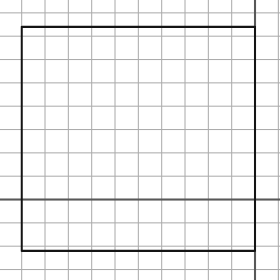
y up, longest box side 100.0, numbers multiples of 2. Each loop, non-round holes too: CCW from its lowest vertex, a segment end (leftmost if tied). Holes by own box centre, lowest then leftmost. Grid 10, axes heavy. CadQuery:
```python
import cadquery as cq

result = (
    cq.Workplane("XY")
    .moveTo(-100.0, -22.0)
    .lineTo(0.0, -22.0)
    .lineTo(0.0, 74.0)
    .lineTo(-100.0, 74.0)
    .close()
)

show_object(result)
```